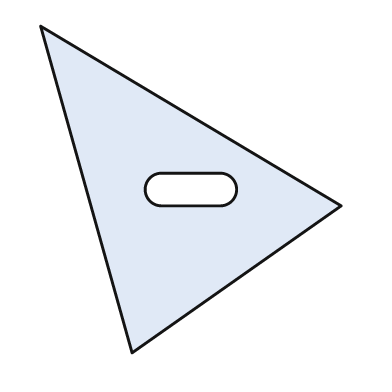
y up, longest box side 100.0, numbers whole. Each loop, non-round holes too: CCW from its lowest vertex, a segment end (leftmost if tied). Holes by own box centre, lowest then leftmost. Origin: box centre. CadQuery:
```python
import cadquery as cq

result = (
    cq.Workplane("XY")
    .moveTo(-18.0, -50.0)
    .lineTo(46.0, -5.0)
    .lineTo(-46.0, 50.0)
    .close()
    .moveTo(-9.0, -5.0)
    .lineTo(9.0, -5.0)
    .threePointArc((14.0, 0.0), (9.0, 5.0))
    .lineTo(-9.0, 5.0)
    .threePointArc((-14.0, 0.0), (-9.0, -5.0))
    .close()
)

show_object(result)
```